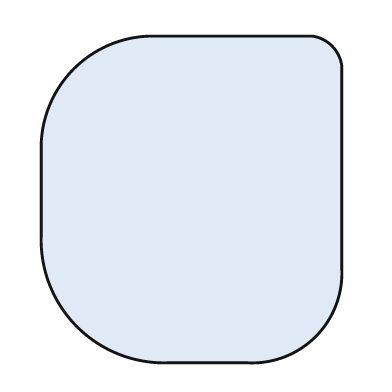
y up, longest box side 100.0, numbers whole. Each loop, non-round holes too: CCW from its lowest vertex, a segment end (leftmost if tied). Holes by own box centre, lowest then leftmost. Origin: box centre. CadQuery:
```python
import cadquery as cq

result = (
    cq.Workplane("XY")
    .moveTo(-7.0, -50.0)
    .lineTo(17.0, -50.0)
    .threePointArc((38.0, -42.0), (46.0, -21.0))
    .lineTo(46.0, 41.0)
    .threePointArc((43.0, 47.0), (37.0, 50.0))
    .lineTo(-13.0, 50.0)
    .threePointArc((-36.0, 40.0), (-46.0, 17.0))
    .lineTo(-46.0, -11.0)
    .threePointArc((-35.0, -39.0), (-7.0, -50.0))
    .close()
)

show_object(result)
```